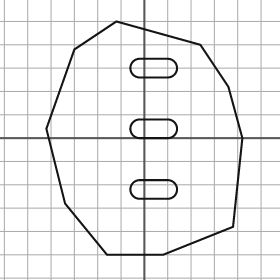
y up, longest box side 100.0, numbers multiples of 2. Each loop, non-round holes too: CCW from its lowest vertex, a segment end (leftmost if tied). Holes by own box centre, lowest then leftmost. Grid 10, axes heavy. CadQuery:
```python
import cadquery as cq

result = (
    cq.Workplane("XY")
    .moveTo(-16.0, -50.0)
    .lineTo(8.0, -50.0)
    .lineTo(38.0, -38.0)
    .lineTo(42.0, 0.0)
    .lineTo(36.0, 22.0)
    .lineTo(24.0, 40.0)
    .lineTo(-12.0, 50.0)
    .lineTo(-30.0, 38.0)
    .lineTo(-42.0, 4.0)
    .lineTo(-34.0, -28.0)
    .close()
    .moveTo(-2.0, -26.0)
    .lineTo(10.0, -26.0)
    .threePointArc((14.0, -22.0), (10.0, -18.0))
    .lineTo(-2.0, -18.0)
    .threePointArc((-6.0, -22.0), (-2.0, -26.0))
    .close()
    .moveTo(-2.0, 0.0)
    .lineTo(10.0, 0.0)
    .threePointArc((14.0, 4.0), (10.0, 8.0))
    .lineTo(-2.0, 8.0)
    .threePointArc((-6.0, 4.0), (-2.0, 0.0))
    .close()
    .moveTo(-2.0, 26.0)
    .lineTo(10.0, 26.0)
    .threePointArc((14.0, 30.0), (10.0, 34.0))
    .lineTo(-2.0, 34.0)
    .threePointArc((-6.0, 30.0), (-2.0, 26.0))
    .close()
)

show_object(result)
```